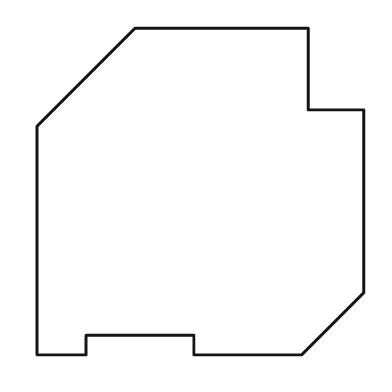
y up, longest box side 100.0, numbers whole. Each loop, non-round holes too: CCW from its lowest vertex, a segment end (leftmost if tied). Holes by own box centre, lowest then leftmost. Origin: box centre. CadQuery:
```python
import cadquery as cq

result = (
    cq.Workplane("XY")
    .moveTo(-50.0, -50.0)
    .lineTo(-35.0, -50.0)
    .lineTo(-35.0, -44.0)
    .lineTo(-2.0, -44.0)
    .lineTo(-2.0, -50.0)
    .lineTo(31.0, -50.0)
    .lineTo(50.0, -31.0)
    .lineTo(50.0, 25.0)
    .lineTo(33.0, 25.0)
    .lineTo(33.0, 50.0)
    .lineTo(-20.0, 50.0)
    .lineTo(-50.0, 20.0)
    .close()
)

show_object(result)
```